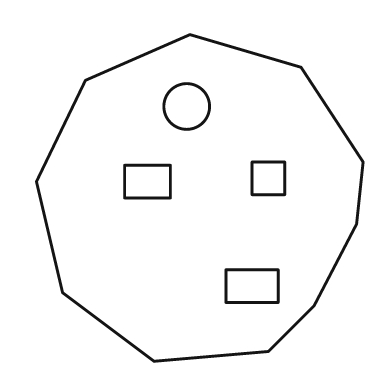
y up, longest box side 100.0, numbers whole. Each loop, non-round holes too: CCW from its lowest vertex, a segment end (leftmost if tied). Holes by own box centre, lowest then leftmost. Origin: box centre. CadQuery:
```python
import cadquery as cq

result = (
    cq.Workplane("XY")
    .moveTo(-14.0, -50.0)
    .lineTo(21.0, -47.0)
    .lineTo(35.0, -33.0)
    .lineTo(48.0, -8.0)
    .lineTo(50.0, 11.0)
    .lineTo(31.0, 40.0)
    .lineTo(-3.0, 50.0)
    .lineTo(-35.0, 36.0)
    .lineTo(-50.0, 5.0)
    .lineTo(-42.0, -29.0)
    .close()
    .moveTo(8.0, -32.0)
    .lineTo(24.0, -32.0)
    .lineTo(24.0, -22.0)
    .lineTo(8.0, -22.0)
    .close()
    .moveTo(-23.0, 0.0)
    .lineTo(-9.0, 0.0)
    .lineTo(-9.0, 10.0)
    .lineTo(-23.0, 10.0)
    .close()
    .moveTo(16.0, 1.0)
    .lineTo(26.0, 1.0)
    .lineTo(26.0, 11.0)
    .lineTo(16.0, 11.0)
    .close()
    .moveTo(-4.0, 28.0)
    .circle(7.0)
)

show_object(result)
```